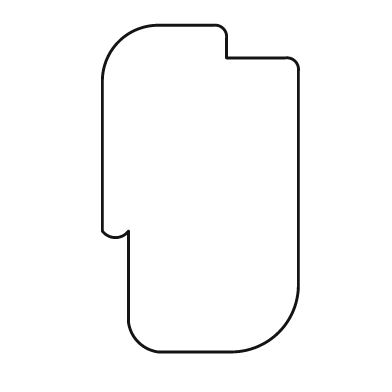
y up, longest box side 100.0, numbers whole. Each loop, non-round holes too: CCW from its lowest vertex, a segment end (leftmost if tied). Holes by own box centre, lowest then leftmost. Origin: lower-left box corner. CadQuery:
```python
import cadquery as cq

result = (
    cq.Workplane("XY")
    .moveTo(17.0, 0.0)
    .lineTo(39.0, 0.0)
    .threePointArc((54.0, 6.0), (60.0, 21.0))
    .lineTo(60.0, 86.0)
    .threePointArc((59.0, 89.0), (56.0, 90.0))
    .lineTo(38.0, 90.0)
    .lineTo(38.0, 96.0)
    .threePointArc((37.0, 99.0), (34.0, 100.0))
    .lineTo(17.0, 100.0)
    .threePointArc((5.0, 95.0), (0.0, 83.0))
    .lineTo(0.0, 37.0)
    .threePointArc((4.0, 35.0), (8.0, 37.0))
    .lineTo(8.0, 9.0)
    .threePointArc((11.0, 3.0), (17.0, 0.0))
    .close()
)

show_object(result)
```